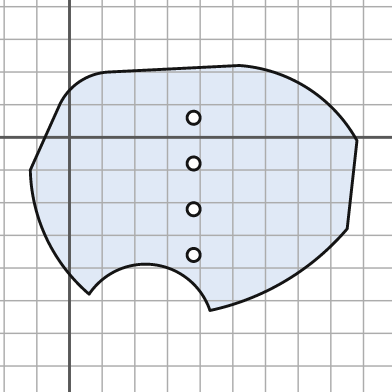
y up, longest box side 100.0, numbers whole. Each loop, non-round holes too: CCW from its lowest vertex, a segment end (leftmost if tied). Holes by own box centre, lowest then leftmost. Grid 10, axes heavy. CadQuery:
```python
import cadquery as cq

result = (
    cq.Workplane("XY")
    .moveTo(43.0, -53.0)
    .threePointArc((66.0, -44.0), (85.0, -28.0))
    .lineTo(88.0, -1.0)
    .threePointArc((73.0, 15.0), (52.0, 22.0))
    .lineTo(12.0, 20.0)
    .threePointArc((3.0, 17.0), (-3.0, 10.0))
    .lineTo(-12.0, -10.0)
    .threePointArc((-7.0, -31.0), (6.0, -48.0))
    .threePointArc((26.0, -39.0), (43.0, -53.0))
    .close()
    .moveTo(38.0, -36.0)
    .circle(2.0)
    .moveTo(38.0, -22.0)
    .circle(2.0)
    .moveTo(38.0, -8.0)
    .circle(2.0)
    .moveTo(38.0, 6.0)
    .circle(2.0)
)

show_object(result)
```